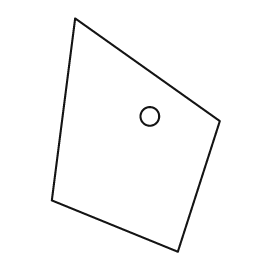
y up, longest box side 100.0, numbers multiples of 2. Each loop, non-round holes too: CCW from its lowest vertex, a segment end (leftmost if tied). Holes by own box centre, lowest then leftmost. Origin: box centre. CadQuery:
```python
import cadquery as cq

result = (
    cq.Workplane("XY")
    .moveTo(18.0, -50.0)
    .lineTo(36.0, 6.0)
    .lineTo(-26.0, 50.0)
    .lineTo(-36.0, -28.0)
    .close()
    .moveTo(6.0, 8.0)
    .circle(4.0)
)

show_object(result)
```